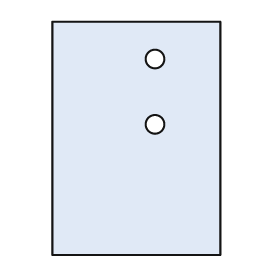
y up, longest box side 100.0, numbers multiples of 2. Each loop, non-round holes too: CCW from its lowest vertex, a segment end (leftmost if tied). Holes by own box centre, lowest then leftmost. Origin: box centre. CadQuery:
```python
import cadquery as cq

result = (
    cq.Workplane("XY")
    .moveTo(-36.0, -50.0)
    .lineTo(36.0, -50.0)
    .lineTo(36.0, 50.0)
    .lineTo(-36.0, 50.0)
    .close()
    .moveTo(8.0, 6.0)
    .circle(4.0)
    .moveTo(8.0, 34.0)
    .circle(4.0)
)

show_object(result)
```